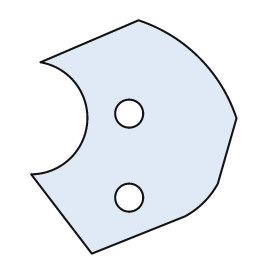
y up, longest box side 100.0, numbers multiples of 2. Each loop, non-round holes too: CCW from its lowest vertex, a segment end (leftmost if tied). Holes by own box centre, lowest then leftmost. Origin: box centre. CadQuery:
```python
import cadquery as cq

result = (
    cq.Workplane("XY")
    .moveTo(-18.0, -50.0)
    .lineTo(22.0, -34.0)
    .threePointArc((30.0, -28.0), (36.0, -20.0))
    .lineTo(44.0, 8.0)
    .threePointArc((28.0, 34.0), (2.0, 50.0))
    .lineTo(-40.0, 32.0)
    .threePointArc((-20.0, 6.0), (-44.0, -16.0))
    .close()
    .moveTo(-2.0, -26.0)
    .circle(6.0)
    .moveTo(-2.0, 10.0)
    .circle(6.0)
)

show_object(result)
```